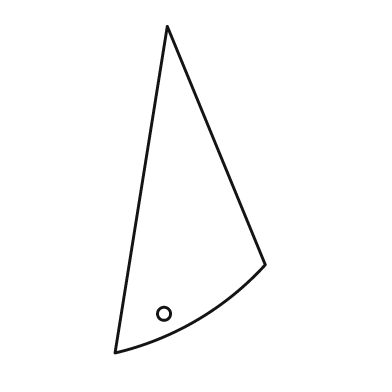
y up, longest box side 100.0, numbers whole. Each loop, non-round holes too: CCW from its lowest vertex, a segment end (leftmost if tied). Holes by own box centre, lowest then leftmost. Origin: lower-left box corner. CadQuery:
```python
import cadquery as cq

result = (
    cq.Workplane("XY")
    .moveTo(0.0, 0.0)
    .threePointArc((25.0, 10.0), (46.0, 27.0))
    .lineTo(16.0, 100.0)
    .close()
    .moveTo(15.0, 12.0)
    .circle(2.0)
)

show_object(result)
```